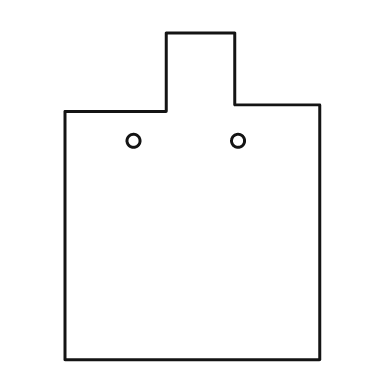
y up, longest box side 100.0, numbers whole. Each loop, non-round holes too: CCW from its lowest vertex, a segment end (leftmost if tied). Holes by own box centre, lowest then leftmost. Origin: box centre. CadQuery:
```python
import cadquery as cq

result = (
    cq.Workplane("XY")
    .moveTo(-39.0, -50.0)
    .lineTo(39.0, -50.0)
    .lineTo(39.0, 28.0)
    .lineTo(13.0, 28.0)
    .lineTo(13.0, 50.0)
    .lineTo(-8.0, 50.0)
    .lineTo(-8.0, 26.0)
    .lineTo(-39.0, 26.0)
    .close()
    .moveTo(-18.0, 17.0)
    .circle(2.0)
    .moveTo(14.0, 17.0)
    .circle(2.0)
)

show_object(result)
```